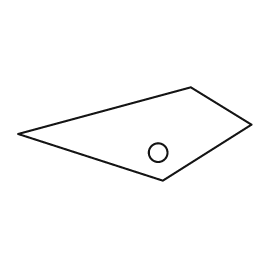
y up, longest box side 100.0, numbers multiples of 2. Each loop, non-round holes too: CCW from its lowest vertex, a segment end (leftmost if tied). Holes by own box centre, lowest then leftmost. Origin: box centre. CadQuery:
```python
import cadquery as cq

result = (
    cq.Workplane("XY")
    .moveTo(12.0, -20.0)
    .lineTo(50.0, 4.0)
    .lineTo(24.0, 20.0)
    .lineTo(-50.0, 0.0)
    .close()
    .moveTo(10.0, -8.0)
    .circle(4.0)
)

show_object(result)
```